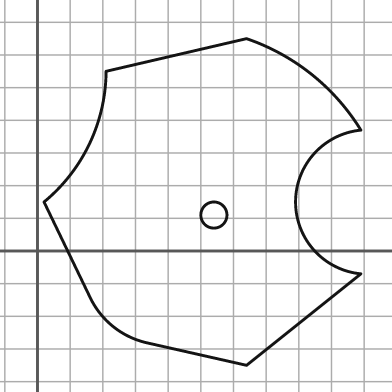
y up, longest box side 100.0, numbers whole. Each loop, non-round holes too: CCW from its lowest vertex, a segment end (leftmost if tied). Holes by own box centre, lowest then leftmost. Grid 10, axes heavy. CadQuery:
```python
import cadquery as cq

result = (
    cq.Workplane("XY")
    .moveTo(64.0, -35.0)
    .lineTo(99.0, -7.0)
    .threePointArc((79.0, 15.0), (99.0, 37.0))
    .threePointArc((84.0, 54.0), (64.0, 65.0))
    .lineTo(21.0, 55.0)
    .threePointArc((16.0, 33.0), (2.0, 15.0))
    .lineTo(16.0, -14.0)
    .threePointArc((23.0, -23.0), (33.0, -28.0))
    .close()
    .moveTo(54.0, 11.0)
    .circle(4.0)
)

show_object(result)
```